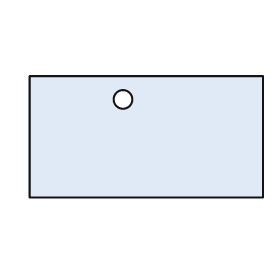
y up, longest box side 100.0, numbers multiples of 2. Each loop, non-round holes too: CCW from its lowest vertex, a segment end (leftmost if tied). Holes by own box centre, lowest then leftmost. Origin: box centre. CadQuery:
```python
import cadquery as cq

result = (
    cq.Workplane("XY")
    .moveTo(-50.0, -26.0)
    .lineTo(50.0, -26.0)
    .lineTo(50.0, 26.0)
    .lineTo(-50.0, 26.0)
    .close()
    .moveTo(-10.0, 16.0)
    .circle(4.0)
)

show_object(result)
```